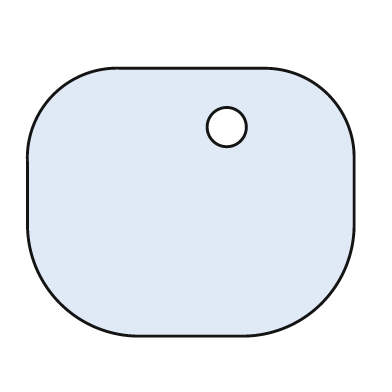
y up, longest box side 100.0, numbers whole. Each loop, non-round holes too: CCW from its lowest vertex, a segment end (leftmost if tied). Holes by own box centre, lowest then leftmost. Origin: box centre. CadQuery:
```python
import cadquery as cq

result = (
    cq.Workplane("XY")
    .moveTo(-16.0, -41.0)
    .lineTo(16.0, -41.0)
    .threePointArc((40.0, -31.0), (50.0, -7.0))
    .lineTo(50.0, 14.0)
    .threePointArc((42.0, 33.0), (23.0, 41.0))
    .lineTo(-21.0, 41.0)
    .threePointArc((-42.0, 33.0), (-50.0, 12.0))
    .lineTo(-50.0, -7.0)
    .threePointArc((-40.0, -31.0), (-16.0, -41.0))
    .close()
    .moveTo(11.0, 23.0)
    .circle(6.0)
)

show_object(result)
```